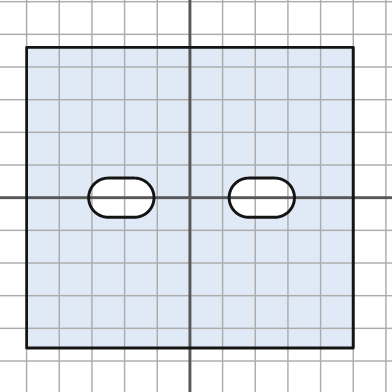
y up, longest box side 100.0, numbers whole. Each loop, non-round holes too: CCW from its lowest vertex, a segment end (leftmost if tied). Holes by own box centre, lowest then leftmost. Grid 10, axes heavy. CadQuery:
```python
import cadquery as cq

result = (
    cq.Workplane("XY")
    .moveTo(-50.0, -46.0)
    .lineTo(50.0, -46.0)
    .lineTo(50.0, 46.0)
    .lineTo(-50.0, 46.0)
    .close()
    .moveTo(-25.0, -6.0)
    .lineTo(-17.0, -6.0)
    .threePointArc((-11.0, 0.0), (-17.0, 6.0))
    .lineTo(-25.0, 6.0)
    .threePointArc((-31.0, 0.0), (-25.0, -6.0))
    .close()
    .moveTo(18.0, -6.0)
    .lineTo(26.0, -6.0)
    .threePointArc((32.0, 0.0), (26.0, 6.0))
    .lineTo(18.0, 6.0)
    .threePointArc((12.0, 0.0), (18.0, -6.0))
    .close()
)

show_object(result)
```